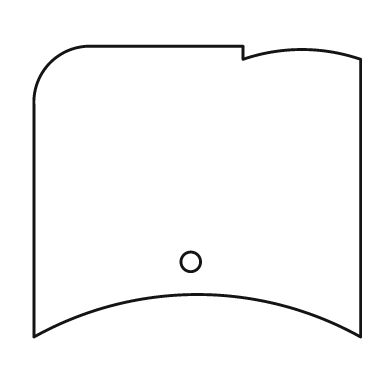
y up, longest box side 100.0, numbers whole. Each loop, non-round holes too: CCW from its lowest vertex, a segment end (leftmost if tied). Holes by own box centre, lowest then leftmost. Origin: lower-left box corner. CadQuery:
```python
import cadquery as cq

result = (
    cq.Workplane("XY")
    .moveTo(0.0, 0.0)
    .threePointArc((50.0, 13.0), (100.0, 0.0))
    .lineTo(100.0, 85.0)
    .threePointArc((82.0, 88.0), (64.0, 85.0))
    .lineTo(64.0, 89.0)
    .lineTo(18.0, 89.0)
    .threePointArc((5.0, 84.0), (0.0, 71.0))
    .close()
    .moveTo(48.0, 23.0)
    .circle(3.0)
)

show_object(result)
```